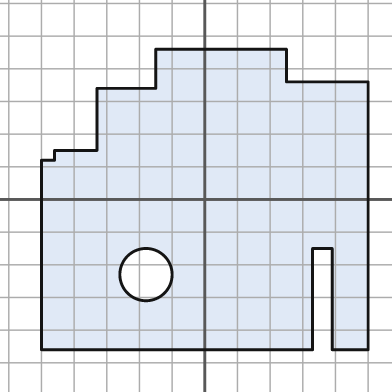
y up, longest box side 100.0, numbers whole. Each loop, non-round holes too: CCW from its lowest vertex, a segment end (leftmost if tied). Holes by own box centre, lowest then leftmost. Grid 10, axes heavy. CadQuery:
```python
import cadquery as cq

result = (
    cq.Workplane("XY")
    .moveTo(-50.0, -46.0)
    .lineTo(33.0, -46.0)
    .lineTo(33.0, -15.0)
    .lineTo(39.0, -15.0)
    .lineTo(39.0, -46.0)
    .lineTo(50.0, -46.0)
    .lineTo(50.0, 36.0)
    .lineTo(25.0, 36.0)
    .lineTo(25.0, 46.0)
    .lineTo(-15.0, 46.0)
    .lineTo(-15.0, 34.0)
    .lineTo(-33.0, 34.0)
    .lineTo(-33.0, 15.0)
    .lineTo(-46.0, 15.0)
    .lineTo(-46.0, 12.0)
    .lineTo(-50.0, 12.0)
    .close()
    .moveTo(-18.0, -23.0)
    .circle(8.0)
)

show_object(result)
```